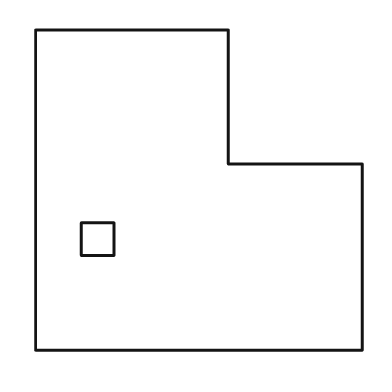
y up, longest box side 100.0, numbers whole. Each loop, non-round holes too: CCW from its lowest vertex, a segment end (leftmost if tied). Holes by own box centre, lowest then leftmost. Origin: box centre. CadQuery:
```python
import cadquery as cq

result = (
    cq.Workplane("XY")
    .moveTo(-50.0, -49.0)
    .lineTo(50.0, -49.0)
    .lineTo(50.0, 8.0)
    .lineTo(9.0, 8.0)
    .lineTo(9.0, 49.0)
    .lineTo(-50.0, 49.0)
    .close()
    .moveTo(-36.0, -20.0)
    .lineTo(-26.0, -20.0)
    .lineTo(-26.0, -10.0)
    .lineTo(-36.0, -10.0)
    .close()
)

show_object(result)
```